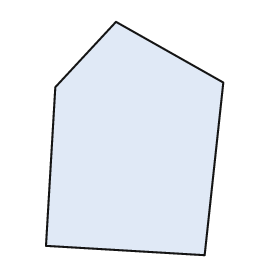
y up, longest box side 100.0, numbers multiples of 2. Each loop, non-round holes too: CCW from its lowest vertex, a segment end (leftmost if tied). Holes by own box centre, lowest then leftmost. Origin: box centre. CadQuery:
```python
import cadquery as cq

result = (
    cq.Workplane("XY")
    .moveTo(30.0, -50.0)
    .lineTo(38.0, 24.0)
    .lineTo(-8.0, 50.0)
    .lineTo(-34.0, 22.0)
    .lineTo(-38.0, -46.0)
    .close()
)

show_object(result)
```